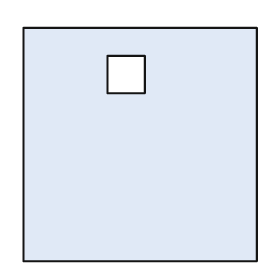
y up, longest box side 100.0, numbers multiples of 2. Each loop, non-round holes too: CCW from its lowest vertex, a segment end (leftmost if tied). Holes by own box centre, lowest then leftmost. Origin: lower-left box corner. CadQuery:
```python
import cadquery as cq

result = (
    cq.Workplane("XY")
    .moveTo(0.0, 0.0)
    .lineTo(100.0, 0.0)
    .lineTo(100.0, 100.0)
    .lineTo(0.0, 100.0)
    .close()
    .moveTo(36.0, 72.0)
    .lineTo(52.0, 72.0)
    .lineTo(52.0, 88.0)
    .lineTo(36.0, 88.0)
    .close()
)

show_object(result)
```